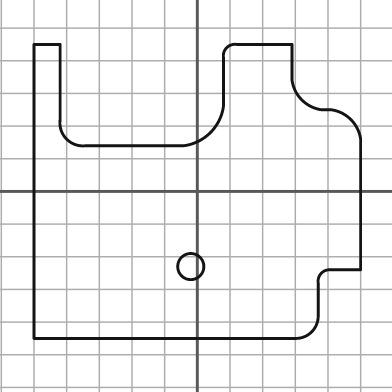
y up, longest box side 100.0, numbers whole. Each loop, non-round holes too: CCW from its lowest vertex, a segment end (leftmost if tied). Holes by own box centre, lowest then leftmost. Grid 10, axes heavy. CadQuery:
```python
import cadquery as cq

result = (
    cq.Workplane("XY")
    .moveTo(-50.0, -45.0)
    .lineTo(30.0, -45.0)
    .threePointArc((35.0, -43.0), (37.0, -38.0))
    .lineTo(37.0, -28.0)
    .threePointArc((38.0, -25.0), (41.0, -24.0))
    .lineTo(50.0, -24.0)
    .lineTo(50.0, 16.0)
    .threePointArc((47.0, 22.0), (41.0, 25.0))
    .lineTo(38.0, 25.0)
    .threePointArc((32.0, 28.0), (29.0, 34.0))
    .lineTo(29.0, 45.0)
    .lineTo(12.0, 45.0)
    .threePointArc((9.0, 44.0), (8.0, 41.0))
    .lineTo(8.0, 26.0)
    .threePointArc((4.0, 18.0), (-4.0, 14.0))
    .lineTo(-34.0, 14.0)
    .threePointArc((-40.0, 16.0), (-42.0, 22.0))
    .lineTo(-42.0, 45.0)
    .lineTo(-50.0, 45.0)
    .close()
    .moveTo(-2.0, -23.0)
    .circle(4.0)
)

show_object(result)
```